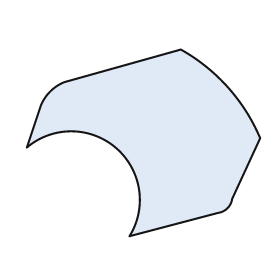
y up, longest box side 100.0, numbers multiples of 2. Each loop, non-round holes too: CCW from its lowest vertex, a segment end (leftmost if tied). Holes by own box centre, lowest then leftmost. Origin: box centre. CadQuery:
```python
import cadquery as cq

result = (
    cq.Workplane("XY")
    .moveTo(-6.0, -40.0)
    .lineTo(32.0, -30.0)
    .threePointArc((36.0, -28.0), (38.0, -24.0))
    .lineTo(50.0, 2.0)
    .threePointArc((36.0, 24.0), (16.0, 40.0))
    .lineTo(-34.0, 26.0)
    .threePointArc((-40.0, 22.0), (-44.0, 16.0))
    .lineTo(-50.0, -2.0)
    .threePointArc((-12.0, -2.0), (-6.0, -40.0))
    .close()
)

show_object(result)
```